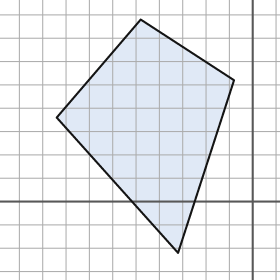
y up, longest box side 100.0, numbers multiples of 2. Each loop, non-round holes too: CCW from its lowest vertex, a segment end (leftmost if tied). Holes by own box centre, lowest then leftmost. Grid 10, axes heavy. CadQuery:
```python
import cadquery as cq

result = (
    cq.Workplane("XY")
    .moveTo(-32.0, -22.0)
    .lineTo(-8.0, 52.0)
    .lineTo(-48.0, 78.0)
    .lineTo(-84.0, 36.0)
    .close()
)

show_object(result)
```